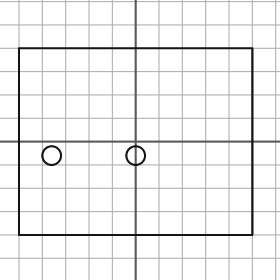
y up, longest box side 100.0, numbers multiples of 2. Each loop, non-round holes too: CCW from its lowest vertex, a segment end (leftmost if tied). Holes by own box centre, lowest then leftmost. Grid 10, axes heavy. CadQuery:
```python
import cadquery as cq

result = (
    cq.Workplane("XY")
    .moveTo(-50.0, -40.0)
    .lineTo(50.0, -40.0)
    .lineTo(50.0, 40.0)
    .lineTo(-50.0, 40.0)
    .close()
    .moveTo(-36.0, -6.0)
    .circle(4.0)
    .moveTo(0.0, -6.0)
    .circle(4.0)
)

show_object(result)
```